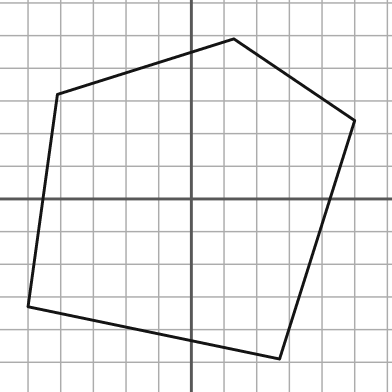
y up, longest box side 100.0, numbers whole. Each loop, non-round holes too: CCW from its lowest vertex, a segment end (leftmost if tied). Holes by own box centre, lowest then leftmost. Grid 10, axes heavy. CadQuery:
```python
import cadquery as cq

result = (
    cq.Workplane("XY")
    .moveTo(27.0, -49.0)
    .lineTo(50.0, 24.0)
    .lineTo(13.0, 49.0)
    .lineTo(-41.0, 32.0)
    .lineTo(-50.0, -33.0)
    .close()
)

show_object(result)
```